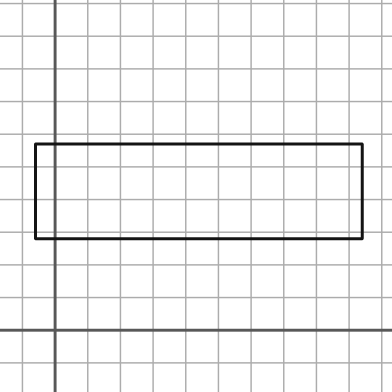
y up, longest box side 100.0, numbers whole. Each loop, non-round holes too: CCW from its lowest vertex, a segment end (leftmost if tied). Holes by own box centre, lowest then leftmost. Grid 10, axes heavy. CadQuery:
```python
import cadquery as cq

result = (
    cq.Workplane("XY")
    .moveTo(-6.0, 28.0)
    .lineTo(94.0, 28.0)
    .lineTo(94.0, 57.0)
    .lineTo(-6.0, 57.0)
    .close()
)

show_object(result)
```